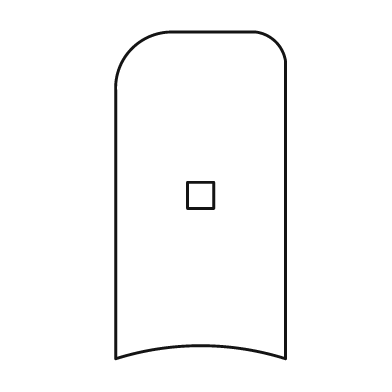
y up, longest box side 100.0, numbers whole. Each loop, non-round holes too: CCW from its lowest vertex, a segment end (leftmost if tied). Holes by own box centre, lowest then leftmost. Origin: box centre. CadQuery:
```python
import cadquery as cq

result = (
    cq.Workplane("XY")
    .moveTo(-26.0, -50.0)
    .threePointArc((0.0, -46.0), (26.0, -50.0))
    .lineTo(26.0, 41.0)
    .threePointArc((23.0, 47.0), (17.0, 50.0))
    .lineTo(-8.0, 50.0)
    .threePointArc((-21.0, 45.0), (-26.0, 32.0))
    .close()
    .moveTo(-4.0, -4.0)
    .lineTo(4.0, -4.0)
    .lineTo(4.0, 4.0)
    .lineTo(-4.0, 4.0)
    .close()
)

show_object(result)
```